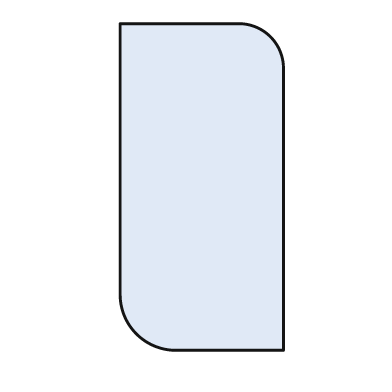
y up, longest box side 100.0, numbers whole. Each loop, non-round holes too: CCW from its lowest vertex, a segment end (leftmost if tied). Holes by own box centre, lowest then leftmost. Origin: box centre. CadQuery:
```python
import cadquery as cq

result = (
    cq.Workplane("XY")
    .moveTo(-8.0, -50.0)
    .lineTo(25.0, -50.0)
    .lineTo(25.0, 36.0)
    .threePointArc((21.0, 46.0), (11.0, 50.0))
    .lineTo(-25.0, 50.0)
    .lineTo(-25.0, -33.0)
    .threePointArc((-20.0, -45.0), (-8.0, -50.0))
    .close()
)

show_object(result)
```